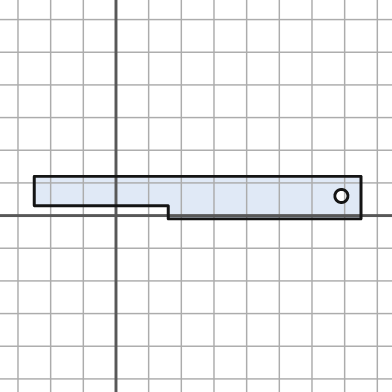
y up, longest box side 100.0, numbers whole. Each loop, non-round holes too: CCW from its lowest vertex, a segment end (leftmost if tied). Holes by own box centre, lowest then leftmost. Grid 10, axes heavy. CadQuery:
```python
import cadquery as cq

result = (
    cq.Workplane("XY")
    .moveTo(16.0, -1.0)
    .lineTo(75.0, -1.0)
    .lineTo(75.0, 12.0)
    .lineTo(-25.0, 12.0)
    .lineTo(-25.0, 3.0)
    .lineTo(16.0, 3.0)
    .close()
    .moveTo(69.0, 6.0)
    .circle(2.0)
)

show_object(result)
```